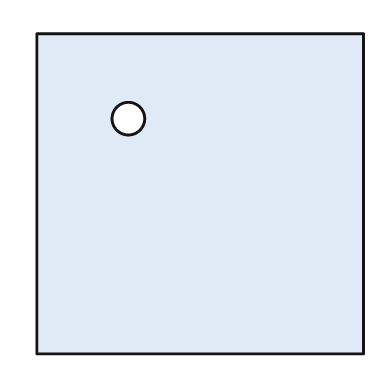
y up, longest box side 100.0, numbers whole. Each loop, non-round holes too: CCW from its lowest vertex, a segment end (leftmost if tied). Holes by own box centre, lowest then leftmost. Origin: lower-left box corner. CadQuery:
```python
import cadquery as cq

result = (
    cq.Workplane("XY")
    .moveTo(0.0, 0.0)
    .lineTo(100.0, 0.0)
    .lineTo(100.0, 98.0)
    .lineTo(0.0, 98.0)
    .close()
    .moveTo(28.0, 72.0)
    .circle(5.0)
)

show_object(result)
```